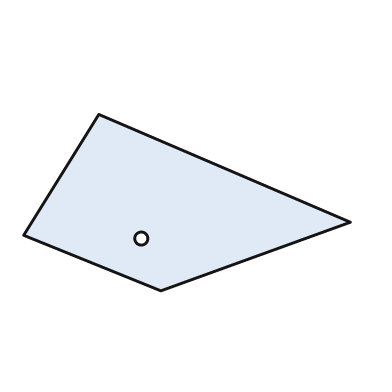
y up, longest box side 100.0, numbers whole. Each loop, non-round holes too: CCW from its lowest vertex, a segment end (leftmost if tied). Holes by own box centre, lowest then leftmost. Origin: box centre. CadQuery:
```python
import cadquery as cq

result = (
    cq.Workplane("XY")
    .moveTo(-8.0, -27.0)
    .lineTo(50.0, -6.0)
    .lineTo(-27.0, 27.0)
    .lineTo(-50.0, -10.0)
    .close()
    .moveTo(-14.0, -11.0)
    .circle(2.0)
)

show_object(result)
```